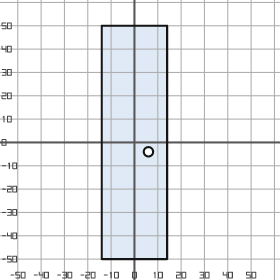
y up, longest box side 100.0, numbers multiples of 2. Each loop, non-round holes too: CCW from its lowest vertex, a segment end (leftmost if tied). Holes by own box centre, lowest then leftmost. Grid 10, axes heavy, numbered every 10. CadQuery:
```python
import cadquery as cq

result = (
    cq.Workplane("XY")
    .moveTo(-14.0, -50.0)
    .lineTo(14.0, -50.0)
    .lineTo(14.0, 50.0)
    .lineTo(-14.0, 50.0)
    .close()
    .moveTo(6.0, -4.0)
    .circle(2.0)
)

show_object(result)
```